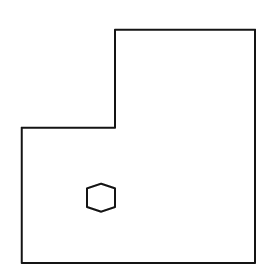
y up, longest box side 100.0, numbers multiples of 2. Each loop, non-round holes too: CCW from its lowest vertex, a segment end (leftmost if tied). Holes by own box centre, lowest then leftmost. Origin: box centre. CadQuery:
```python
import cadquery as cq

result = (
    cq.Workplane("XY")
    .moveTo(-50.0, -50.0)
    .lineTo(50.0, -50.0)
    .lineTo(50.0, 50.0)
    .lineTo(-10.0, 50.0)
    .lineTo(-10.0, 8.0)
    .lineTo(-50.0, 8.0)
    .close()
    .moveTo(-16.0, -28.0)
    .lineTo(-10.0, -26.0)
    .lineTo(-10.0, -18.0)
    .lineTo(-16.0, -16.0)
    .lineTo(-22.0, -18.0)
    .lineTo(-22.0, -26.0)
    .close()
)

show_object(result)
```